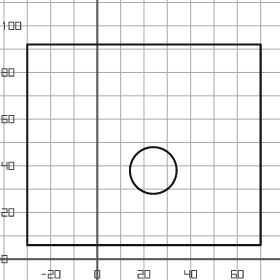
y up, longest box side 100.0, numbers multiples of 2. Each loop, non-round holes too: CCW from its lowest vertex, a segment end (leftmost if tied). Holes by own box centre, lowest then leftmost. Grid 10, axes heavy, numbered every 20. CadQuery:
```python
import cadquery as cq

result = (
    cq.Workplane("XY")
    .moveTo(-30.0, 6.0)
    .lineTo(70.0, 6.0)
    .lineTo(70.0, 92.0)
    .lineTo(-30.0, 92.0)
    .close()
    .moveTo(24.0, 38.0)
    .circle(10.0)
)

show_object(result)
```